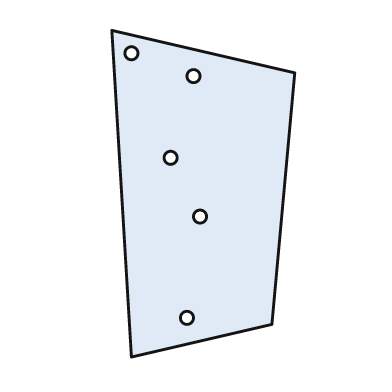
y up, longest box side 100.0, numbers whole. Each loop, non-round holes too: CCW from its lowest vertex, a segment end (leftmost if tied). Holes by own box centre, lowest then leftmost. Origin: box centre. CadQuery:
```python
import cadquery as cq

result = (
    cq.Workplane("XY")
    .moveTo(-22.0, -50.0)
    .lineTo(21.0, -40.0)
    .lineTo(28.0, 37.0)
    .lineTo(-28.0, 50.0)
    .close()
    .moveTo(-5.0, -38.0)
    .circle(2.0)
    .moveTo(-1.0, -7.0)
    .circle(2.0)
    .moveTo(-10.0, 11.0)
    .circle(2.0)
    .moveTo(-3.0, 36.0)
    .circle(2.0)
    .moveTo(-22.0, 43.0)
    .circle(2.0)
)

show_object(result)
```